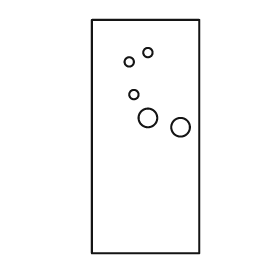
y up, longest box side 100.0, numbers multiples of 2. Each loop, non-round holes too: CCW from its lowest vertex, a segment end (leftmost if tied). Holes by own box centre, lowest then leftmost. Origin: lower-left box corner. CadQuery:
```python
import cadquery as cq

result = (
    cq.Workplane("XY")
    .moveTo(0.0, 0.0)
    .lineTo(46.0, 0.0)
    .lineTo(46.0, 100.0)
    .lineTo(0.0, 100.0)
    .close()
    .moveTo(38.0, 54.0)
    .circle(4.0)
    .moveTo(24.0, 58.0)
    .circle(4.0)
    .moveTo(18.0, 68.0)
    .circle(2.0)
    .moveTo(16.0, 82.0)
    .circle(2.0)
    .moveTo(24.0, 86.0)
    .circle(2.0)
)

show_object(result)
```